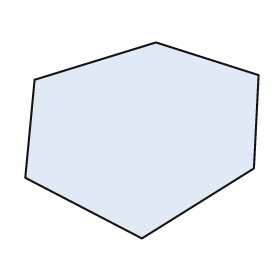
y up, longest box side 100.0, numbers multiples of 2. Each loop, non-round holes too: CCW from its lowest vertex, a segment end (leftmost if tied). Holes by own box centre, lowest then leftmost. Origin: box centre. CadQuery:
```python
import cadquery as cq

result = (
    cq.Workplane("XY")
    .moveTo(0.0, -42.0)
    .lineTo(48.0, -12.0)
    .lineTo(50.0, 28.0)
    .lineTo(6.0, 42.0)
    .lineTo(-46.0, 26.0)
    .lineTo(-50.0, -16.0)
    .close()
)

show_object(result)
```